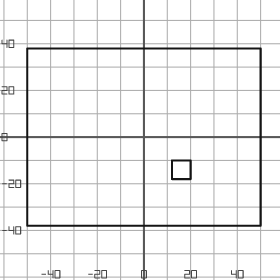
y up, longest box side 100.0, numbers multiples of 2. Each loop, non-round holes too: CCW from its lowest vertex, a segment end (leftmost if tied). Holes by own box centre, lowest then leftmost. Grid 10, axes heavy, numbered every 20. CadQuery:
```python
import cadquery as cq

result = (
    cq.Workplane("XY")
    .moveTo(-50.0, -38.0)
    .lineTo(50.0, -38.0)
    .lineTo(50.0, 38.0)
    .lineTo(-50.0, 38.0)
    .close()
    .moveTo(12.0, -18.0)
    .lineTo(20.0, -18.0)
    .lineTo(20.0, -10.0)
    .lineTo(12.0, -10.0)
    .close()
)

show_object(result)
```